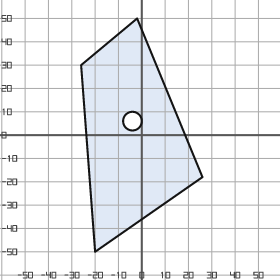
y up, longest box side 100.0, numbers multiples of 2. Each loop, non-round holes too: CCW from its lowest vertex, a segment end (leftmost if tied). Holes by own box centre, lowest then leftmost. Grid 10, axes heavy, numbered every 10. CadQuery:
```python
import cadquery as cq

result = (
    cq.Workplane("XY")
    .moveTo(-20.0, -50.0)
    .lineTo(26.0, -18.0)
    .lineTo(-2.0, 50.0)
    .lineTo(-26.0, 30.0)
    .close()
    .moveTo(-4.0, 6.0)
    .circle(4.0)
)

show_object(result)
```